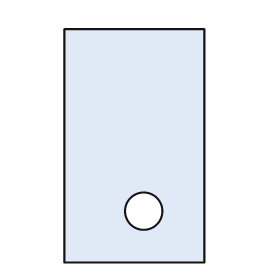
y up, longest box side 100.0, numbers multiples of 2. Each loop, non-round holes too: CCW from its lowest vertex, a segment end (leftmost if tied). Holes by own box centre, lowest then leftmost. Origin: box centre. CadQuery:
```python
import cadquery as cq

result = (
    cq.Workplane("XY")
    .moveTo(-30.0, -50.0)
    .lineTo(30.0, -50.0)
    .lineTo(30.0, 50.0)
    .lineTo(-30.0, 50.0)
    .close()
    .moveTo(4.0, -28.0)
    .circle(8.0)
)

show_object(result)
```